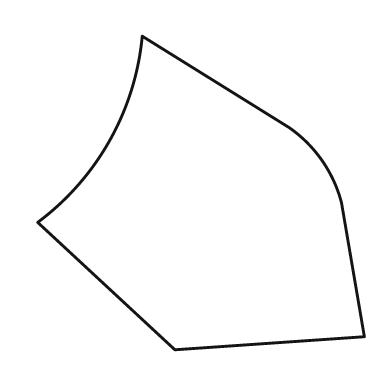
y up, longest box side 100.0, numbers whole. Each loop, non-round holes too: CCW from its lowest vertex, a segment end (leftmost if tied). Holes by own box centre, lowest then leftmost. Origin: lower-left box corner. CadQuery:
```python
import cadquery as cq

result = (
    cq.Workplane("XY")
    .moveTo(42.0, 0.0)
    .lineTo(100.0, 4.0)
    .lineTo(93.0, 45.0)
    .threePointArc((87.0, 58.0), (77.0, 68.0))
    .lineTo(32.0, 96.0)
    .threePointArc((22.0, 64.0), (0.0, 39.0))
    .close()
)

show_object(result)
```